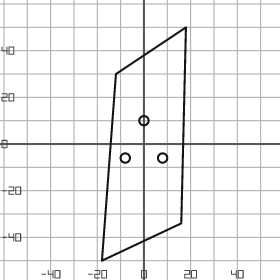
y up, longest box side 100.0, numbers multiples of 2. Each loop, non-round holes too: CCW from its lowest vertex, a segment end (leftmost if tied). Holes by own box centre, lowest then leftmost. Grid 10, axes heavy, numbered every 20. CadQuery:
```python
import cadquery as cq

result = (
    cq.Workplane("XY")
    .moveTo(-18.0, -50.0)
    .lineTo(16.0, -34.0)
    .lineTo(18.0, 50.0)
    .lineTo(-12.0, 30.0)
    .close()
    .moveTo(-8.0, -6.0)
    .circle(2.0)
    .moveTo(8.0, -6.0)
    .circle(2.0)
    .moveTo(0.0, 10.0)
    .circle(2.0)
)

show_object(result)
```